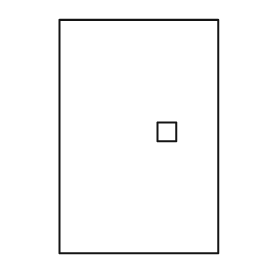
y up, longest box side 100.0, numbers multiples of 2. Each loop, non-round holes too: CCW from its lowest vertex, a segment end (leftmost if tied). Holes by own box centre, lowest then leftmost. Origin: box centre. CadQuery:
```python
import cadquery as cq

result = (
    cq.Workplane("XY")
    .moveTo(-34.0, -50.0)
    .lineTo(34.0, -50.0)
    .lineTo(34.0, 50.0)
    .lineTo(-34.0, 50.0)
    .close()
    .moveTo(8.0, -2.0)
    .lineTo(16.0, -2.0)
    .lineTo(16.0, 6.0)
    .lineTo(8.0, 6.0)
    .close()
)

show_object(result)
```